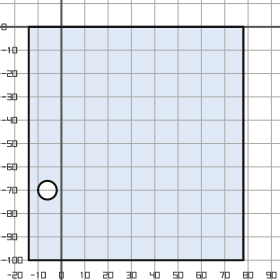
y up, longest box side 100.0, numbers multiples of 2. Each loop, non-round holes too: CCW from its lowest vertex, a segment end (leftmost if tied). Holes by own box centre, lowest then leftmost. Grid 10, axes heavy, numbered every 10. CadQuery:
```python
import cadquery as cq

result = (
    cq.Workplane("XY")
    .moveTo(-14.0, -100.0)
    .lineTo(78.0, -100.0)
    .lineTo(78.0, 0.0)
    .lineTo(-14.0, 0.0)
    .close()
    .moveTo(-6.0, -70.0)
    .circle(4.0)
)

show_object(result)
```